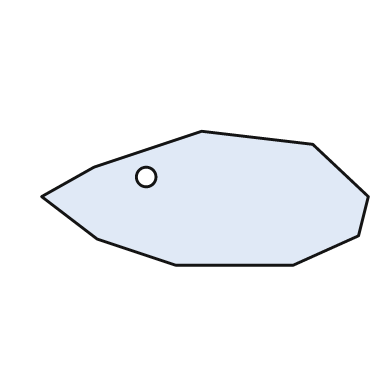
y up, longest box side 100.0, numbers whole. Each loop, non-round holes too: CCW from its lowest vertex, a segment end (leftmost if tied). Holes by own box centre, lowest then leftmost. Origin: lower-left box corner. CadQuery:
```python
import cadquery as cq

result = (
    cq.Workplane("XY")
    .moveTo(41.0, 0.0)
    .lineTo(77.0, 0.0)
    .lineTo(97.0, 9.0)
    .lineTo(100.0, 21.0)
    .lineTo(83.0, 37.0)
    .lineTo(49.0, 41.0)
    .lineTo(16.0, 30.0)
    .lineTo(0.0, 21.0)
    .lineTo(17.0, 8.0)
    .close()
    .moveTo(32.0, 27.0)
    .circle(3.0)
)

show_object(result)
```